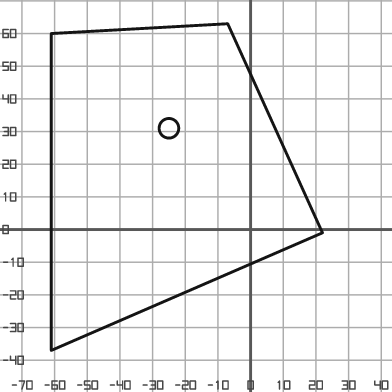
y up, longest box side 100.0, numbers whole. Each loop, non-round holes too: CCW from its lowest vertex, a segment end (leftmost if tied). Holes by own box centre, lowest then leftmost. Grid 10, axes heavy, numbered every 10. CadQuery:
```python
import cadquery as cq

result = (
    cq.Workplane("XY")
    .moveTo(-61.0, -37.0)
    .lineTo(22.0, -1.0)
    .lineTo(-7.0, 63.0)
    .lineTo(-61.0, 60.0)
    .close()
    .moveTo(-25.0, 31.0)
    .circle(3.0)
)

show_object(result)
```